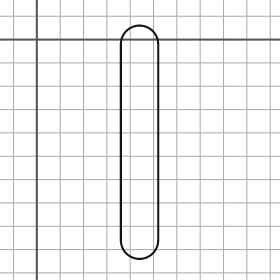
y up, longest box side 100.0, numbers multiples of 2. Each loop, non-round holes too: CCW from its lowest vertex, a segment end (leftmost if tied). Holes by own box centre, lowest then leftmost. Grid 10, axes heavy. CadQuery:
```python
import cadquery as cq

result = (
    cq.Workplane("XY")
    .moveTo(36.0, -86.0)
    .threePointArc((44.0, -94.0), (52.0, -86.0))
    .lineTo(52.0, -2.0)
    .threePointArc((44.0, 6.0), (36.0, -2.0))
    .close()
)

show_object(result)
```